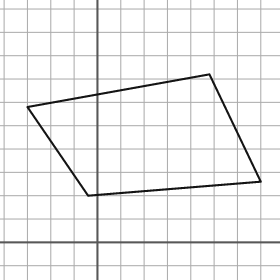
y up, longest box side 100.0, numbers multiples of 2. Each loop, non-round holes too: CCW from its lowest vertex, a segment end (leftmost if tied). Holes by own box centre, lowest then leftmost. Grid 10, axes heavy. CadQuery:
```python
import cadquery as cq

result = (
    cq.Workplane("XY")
    .moveTo(-4.0, 20.0)
    .lineTo(70.0, 26.0)
    .lineTo(48.0, 72.0)
    .lineTo(-30.0, 58.0)
    .close()
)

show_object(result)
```